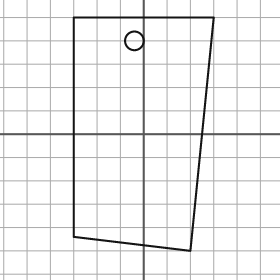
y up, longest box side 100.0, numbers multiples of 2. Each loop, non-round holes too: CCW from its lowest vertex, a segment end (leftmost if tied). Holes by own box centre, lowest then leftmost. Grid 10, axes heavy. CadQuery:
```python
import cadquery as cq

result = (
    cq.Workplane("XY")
    .moveTo(20.0, -50.0)
    .lineTo(30.0, 50.0)
    .lineTo(-30.0, 50.0)
    .lineTo(-30.0, -44.0)
    .close()
    .moveTo(-4.0, 40.0)
    .circle(4.0)
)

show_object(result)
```